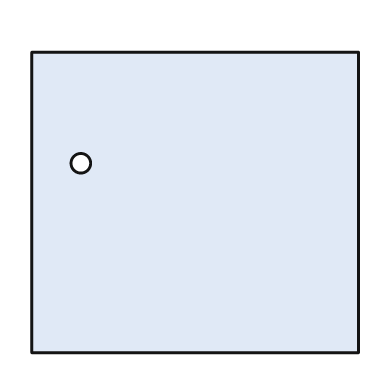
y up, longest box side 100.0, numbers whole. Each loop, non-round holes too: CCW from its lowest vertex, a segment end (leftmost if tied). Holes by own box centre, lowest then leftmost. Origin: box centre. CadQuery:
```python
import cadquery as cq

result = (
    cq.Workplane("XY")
    .moveTo(-50.0, -46.0)
    .lineTo(50.0, -46.0)
    .lineTo(50.0, 46.0)
    .lineTo(-50.0, 46.0)
    .close()
    .moveTo(-35.0, 12.0)
    .circle(3.0)
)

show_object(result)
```